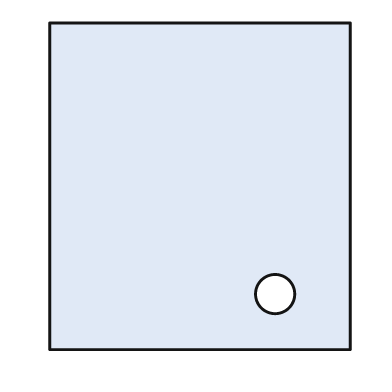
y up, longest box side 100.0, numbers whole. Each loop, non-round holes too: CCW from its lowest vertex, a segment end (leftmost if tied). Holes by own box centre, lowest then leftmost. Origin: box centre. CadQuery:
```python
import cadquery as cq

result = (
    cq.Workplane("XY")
    .moveTo(-46.0, -50.0)
    .lineTo(46.0, -50.0)
    .lineTo(46.0, 50.0)
    .lineTo(-46.0, 50.0)
    .close()
    .moveTo(23.0, -33.0)
    .circle(6.0)
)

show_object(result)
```